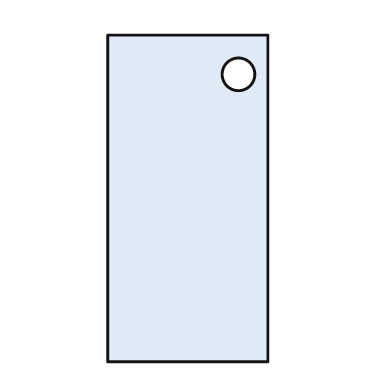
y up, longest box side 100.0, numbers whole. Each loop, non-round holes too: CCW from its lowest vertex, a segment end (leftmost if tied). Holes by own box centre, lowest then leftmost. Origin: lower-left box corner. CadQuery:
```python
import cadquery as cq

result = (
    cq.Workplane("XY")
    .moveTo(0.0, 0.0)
    .lineTo(49.0, 0.0)
    .lineTo(49.0, 100.0)
    .lineTo(0.0, 100.0)
    .close()
    .moveTo(40.0, 88.0)
    .circle(5.0)
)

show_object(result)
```